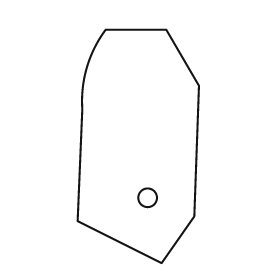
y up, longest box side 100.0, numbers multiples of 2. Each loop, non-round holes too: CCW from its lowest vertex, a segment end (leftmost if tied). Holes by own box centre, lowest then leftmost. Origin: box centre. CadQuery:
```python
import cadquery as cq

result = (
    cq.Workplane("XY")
    .moveTo(10.0, -50.0)
    .lineTo(24.0, -30.0)
    .lineTo(26.0, 26.0)
    .lineTo(12.0, 50.0)
    .lineTo(-14.0, 50.0)
    .threePointArc((-22.0, 34.0), (-24.0, 16.0))
    .lineTo(-26.0, -32.0)
    .close()
    .moveTo(4.0, -22.0)
    .circle(4.0)
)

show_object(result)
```